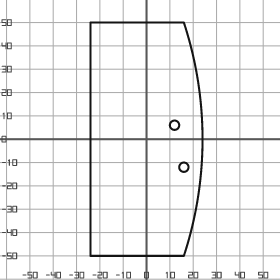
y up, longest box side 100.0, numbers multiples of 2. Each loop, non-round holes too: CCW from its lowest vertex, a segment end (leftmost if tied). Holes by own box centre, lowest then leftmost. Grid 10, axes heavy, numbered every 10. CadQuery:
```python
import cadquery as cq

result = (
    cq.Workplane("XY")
    .moveTo(-24.0, -50.0)
    .lineTo(16.0, -50.0)
    .threePointArc((24.0, 0.0), (16.0, 50.0))
    .lineTo(-24.0, 50.0)
    .close()
    .moveTo(16.0, -12.0)
    .circle(2.0)
    .moveTo(12.0, 6.0)
    .circle(2.0)
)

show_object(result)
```